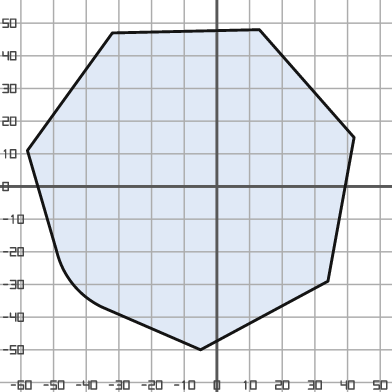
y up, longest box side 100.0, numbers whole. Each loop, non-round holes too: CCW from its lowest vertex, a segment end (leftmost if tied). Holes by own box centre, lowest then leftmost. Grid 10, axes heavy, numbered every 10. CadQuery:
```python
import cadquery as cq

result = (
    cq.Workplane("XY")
    .moveTo(-5.0, -50.0)
    .lineTo(34.0, -29.0)
    .lineTo(42.0, 15.0)
    .lineTo(13.0, 48.0)
    .lineTo(-32.0, 47.0)
    .lineTo(-58.0, 11.0)
    .lineTo(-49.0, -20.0)
    .threePointArc((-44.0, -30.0), (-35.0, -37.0))
    .close()
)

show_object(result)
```